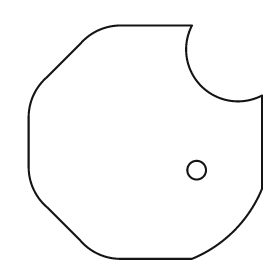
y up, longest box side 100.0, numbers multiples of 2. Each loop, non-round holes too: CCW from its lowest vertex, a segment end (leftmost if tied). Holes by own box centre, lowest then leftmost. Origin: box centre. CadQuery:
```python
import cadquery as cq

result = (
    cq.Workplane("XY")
    .moveTo(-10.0, -50.0)
    .lineTo(20.0, -50.0)
    .threePointArc((38.0, -38.0), (50.0, -20.0))
    .lineTo(50.0, 20.0)
    .threePointArc((24.0, 24.0), (20.0, 50.0))
    .lineTo(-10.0, 50.0)
    .threePointArc((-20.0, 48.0), (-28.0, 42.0))
    .lineTo(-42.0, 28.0)
    .threePointArc((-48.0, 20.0), (-50.0, 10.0))
    .lineTo(-50.0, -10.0)
    .threePointArc((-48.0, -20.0), (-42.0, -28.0))
    .lineTo(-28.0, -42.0)
    .threePointArc((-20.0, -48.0), (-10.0, -50.0))
    .close()
    .moveTo(22.0, -12.0)
    .circle(4.0)
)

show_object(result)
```